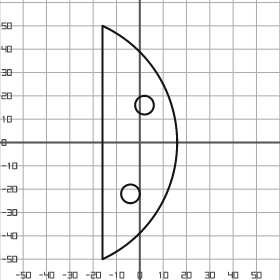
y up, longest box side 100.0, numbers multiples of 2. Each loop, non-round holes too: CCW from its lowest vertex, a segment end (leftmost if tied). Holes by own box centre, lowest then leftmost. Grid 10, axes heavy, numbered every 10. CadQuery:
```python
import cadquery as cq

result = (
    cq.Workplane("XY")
    .moveTo(-16.0, -50.0)
    .threePointArc((16.0, 0.0), (-16.0, 50.0))
    .close()
    .moveTo(-4.0, -22.0)
    .circle(4.0)
    .moveTo(2.0, 16.0)
    .circle(4.0)
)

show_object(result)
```